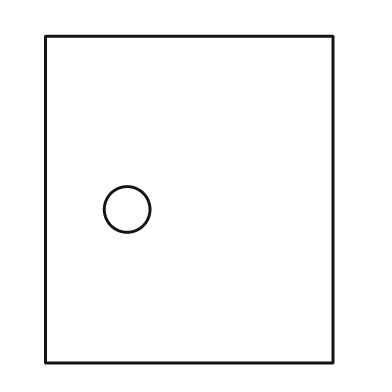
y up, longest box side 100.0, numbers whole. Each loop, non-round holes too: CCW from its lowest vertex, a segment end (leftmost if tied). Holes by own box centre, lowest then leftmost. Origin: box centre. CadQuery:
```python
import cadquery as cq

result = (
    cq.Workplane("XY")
    .moveTo(-44.0, -50.0)
    .lineTo(44.0, -50.0)
    .lineTo(44.0, 50.0)
    .lineTo(-44.0, 50.0)
    .close()
    .moveTo(-19.0, -3.0)
    .circle(7.0)
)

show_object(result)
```